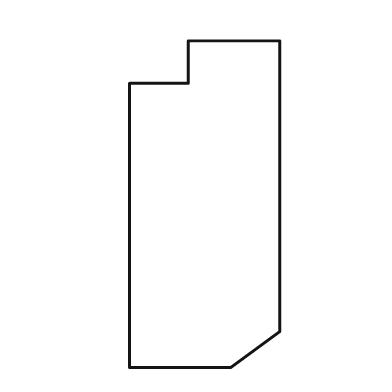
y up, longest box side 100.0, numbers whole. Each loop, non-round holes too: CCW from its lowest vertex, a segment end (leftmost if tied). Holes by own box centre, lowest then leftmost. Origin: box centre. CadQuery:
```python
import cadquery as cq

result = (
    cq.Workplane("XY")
    .moveTo(-23.0, -50.0)
    .lineTo(8.0, -50.0)
    .lineTo(23.0, -39.0)
    .lineTo(23.0, 50.0)
    .lineTo(-5.0, 50.0)
    .lineTo(-5.0, 37.0)
    .lineTo(-23.0, 37.0)
    .close()
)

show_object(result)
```